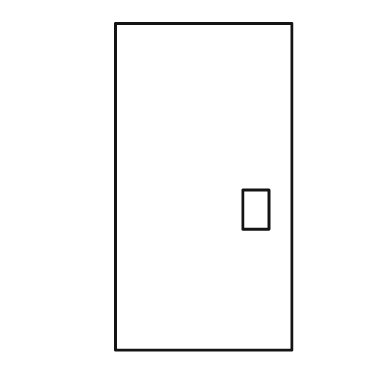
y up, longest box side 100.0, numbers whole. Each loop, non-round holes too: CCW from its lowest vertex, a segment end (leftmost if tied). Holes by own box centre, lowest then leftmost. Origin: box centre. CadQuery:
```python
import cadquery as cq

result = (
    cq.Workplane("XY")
    .moveTo(-27.0, -50.0)
    .lineTo(27.0, -50.0)
    .lineTo(27.0, 50.0)
    .lineTo(-27.0, 50.0)
    .close()
    .moveTo(12.0, -13.0)
    .lineTo(20.0, -13.0)
    .lineTo(20.0, -1.0)
    .lineTo(12.0, -1.0)
    .close()
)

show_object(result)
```